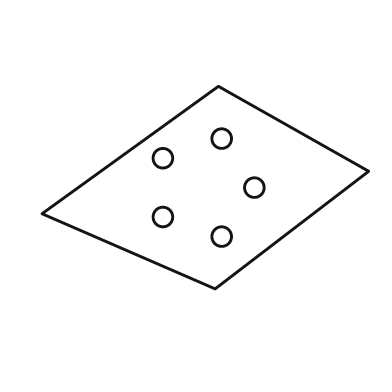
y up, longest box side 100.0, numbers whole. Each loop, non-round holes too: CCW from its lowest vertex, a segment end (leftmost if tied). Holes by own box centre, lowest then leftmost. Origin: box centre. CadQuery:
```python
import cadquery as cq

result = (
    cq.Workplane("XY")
    .moveTo(3.0, -31.0)
    .lineTo(50.0, 5.0)
    .lineTo(4.0, 31.0)
    .lineTo(-50.0, -8.0)
    .close()
    .moveTo(5.0, -15.0)
    .circle(3.0)
    .moveTo(-13.0, -9.0)
    .circle(3.0)
    .moveTo(15.0, 0.0)
    .circle(3.0)
    .moveTo(-13.0, 9.0)
    .circle(3.0)
    .moveTo(5.0, 15.0)
    .circle(3.0)
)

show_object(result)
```